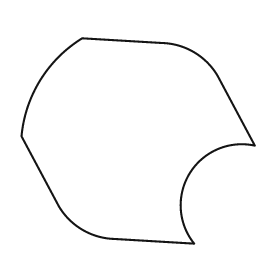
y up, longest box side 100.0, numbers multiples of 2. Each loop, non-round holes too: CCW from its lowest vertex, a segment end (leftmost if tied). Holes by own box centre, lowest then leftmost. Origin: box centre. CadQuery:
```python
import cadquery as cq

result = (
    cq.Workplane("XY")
    .moveTo(24.0, -44.0)
    .threePointArc((22.0, -14.0), (50.0, -2.0))
    .lineTo(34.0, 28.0)
    .threePointArc((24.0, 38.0), (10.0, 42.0))
    .lineTo(-24.0, 44.0)
    .threePointArc((-42.0, 26.0), (-50.0, 2.0))
    .lineTo(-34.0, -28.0)
    .threePointArc((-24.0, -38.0), (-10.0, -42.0))
    .close()
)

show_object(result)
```